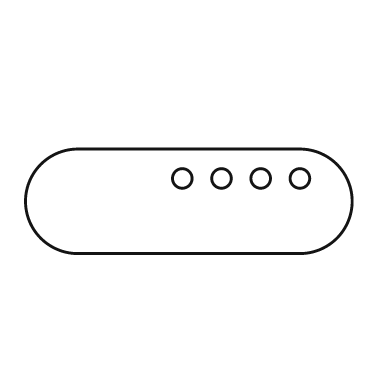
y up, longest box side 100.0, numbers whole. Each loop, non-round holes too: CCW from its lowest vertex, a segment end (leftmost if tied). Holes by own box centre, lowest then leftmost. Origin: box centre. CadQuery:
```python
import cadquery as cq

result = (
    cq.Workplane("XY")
    .moveTo(-34.0, -16.0)
    .lineTo(34.0, -16.0)
    .threePointArc((50.0, 0.0), (34.0, 16.0))
    .lineTo(-34.0, 16.0)
    .threePointArc((-50.0, 0.0), (-34.0, -16.0))
    .close()
    .moveTo(-2.0, 7.0)
    .circle(3.0)
    .moveTo(10.0, 7.0)
    .circle(3.0)
    .moveTo(22.0, 7.0)
    .circle(3.0)
    .moveTo(34.0, 7.0)
    .circle(3.0)
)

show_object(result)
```